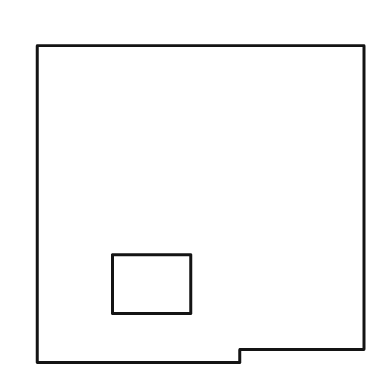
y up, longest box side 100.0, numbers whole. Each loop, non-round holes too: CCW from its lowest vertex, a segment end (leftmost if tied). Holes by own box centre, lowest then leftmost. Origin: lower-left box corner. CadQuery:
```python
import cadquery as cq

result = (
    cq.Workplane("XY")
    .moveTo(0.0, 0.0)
    .lineTo(62.0, 0.0)
    .lineTo(62.0, 4.0)
    .lineTo(100.0, 4.0)
    .lineTo(100.0, 97.0)
    .lineTo(0.0, 97.0)
    .close()
    .moveTo(23.0, 15.0)
    .lineTo(47.0, 15.0)
    .lineTo(47.0, 33.0)
    .lineTo(23.0, 33.0)
    .close()
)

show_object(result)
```